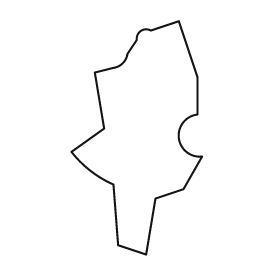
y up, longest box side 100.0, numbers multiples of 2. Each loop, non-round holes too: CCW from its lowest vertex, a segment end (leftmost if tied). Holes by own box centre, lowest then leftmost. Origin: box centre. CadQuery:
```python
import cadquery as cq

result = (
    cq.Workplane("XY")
    .moveTo(4.0, -50.0)
    .lineTo(8.0, -26.0)
    .lineTo(20.0, -22.0)
    .lineTo(28.0, -8.0)
    .threePointArc((18.0, 0.0), (26.0, 10.0))
    .lineTo(26.0, 26.0)
    .lineTo(18.0, 50.0)
    .lineTo(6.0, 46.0)
    .threePointArc((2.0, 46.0), (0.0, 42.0))
    .lineTo(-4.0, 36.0)
    .threePointArc((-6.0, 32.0), (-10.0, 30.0))
    .lineTo(-18.0, 28.0)
    .lineTo(-14.0, 4.0)
    .lineTo(-28.0, -6.0)
    .threePointArc((-20.0, -14.0), (-10.0, -20.0))
    .lineTo(-8.0, -46.0)
    .close()
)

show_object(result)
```